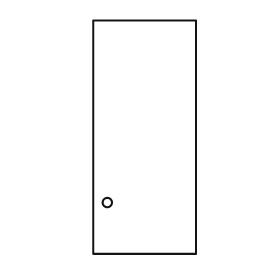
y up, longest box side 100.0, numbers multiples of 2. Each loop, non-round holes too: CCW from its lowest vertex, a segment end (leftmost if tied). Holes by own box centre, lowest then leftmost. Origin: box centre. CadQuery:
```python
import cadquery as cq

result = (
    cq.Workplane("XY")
    .moveTo(-22.0, -50.0)
    .lineTo(22.0, -50.0)
    .lineTo(22.0, 50.0)
    .lineTo(-22.0, 50.0)
    .close()
    .moveTo(-16.0, -28.0)
    .circle(2.0)
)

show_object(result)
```